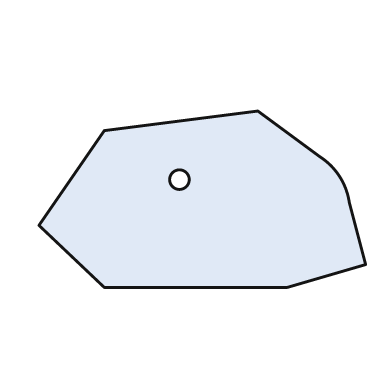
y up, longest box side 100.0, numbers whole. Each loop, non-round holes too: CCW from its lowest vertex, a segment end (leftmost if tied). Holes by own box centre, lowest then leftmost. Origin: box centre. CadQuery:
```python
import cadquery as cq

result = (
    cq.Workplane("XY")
    .moveTo(-30.0, -27.0)
    .lineTo(26.0, -27.0)
    .lineTo(50.0, -20.0)
    .lineTo(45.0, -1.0)
    .threePointArc((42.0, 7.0), (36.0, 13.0))
    .lineTo(17.0, 27.0)
    .lineTo(-30.0, 21.0)
    .lineTo(-50.0, -8.0)
    .close()
    .moveTo(-7.0, 6.0)
    .circle(3.0)
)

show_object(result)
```